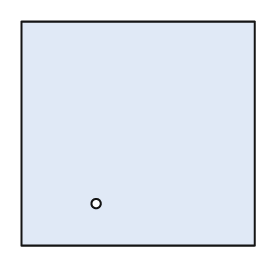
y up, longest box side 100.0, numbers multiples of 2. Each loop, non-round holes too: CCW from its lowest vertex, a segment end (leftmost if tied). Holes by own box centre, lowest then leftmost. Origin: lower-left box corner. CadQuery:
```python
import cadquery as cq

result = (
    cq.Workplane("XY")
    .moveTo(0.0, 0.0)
    .lineTo(100.0, 0.0)
    .lineTo(100.0, 96.0)
    .lineTo(0.0, 96.0)
    .close()
    .moveTo(32.0, 18.0)
    .circle(2.0)
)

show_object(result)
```